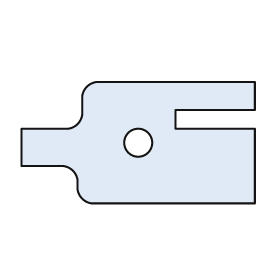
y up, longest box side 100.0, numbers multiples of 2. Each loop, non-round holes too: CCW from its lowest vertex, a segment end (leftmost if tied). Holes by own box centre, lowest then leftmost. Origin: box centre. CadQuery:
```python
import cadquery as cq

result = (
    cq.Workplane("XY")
    .moveTo(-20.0, -26.0)
    .lineTo(50.0, -26.0)
    .lineTo(50.0, 6.0)
    .lineTo(16.0, 6.0)
    .lineTo(16.0, 14.0)
    .lineTo(50.0, 14.0)
    .lineTo(50.0, 26.0)
    .lineTo(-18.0, 26.0)
    .threePointArc((-22.0, 24.0), (-24.0, 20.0))
    .lineTo(-24.0, 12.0)
    .threePointArc((-26.0, 8.0), (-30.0, 6.0))
    .lineTo(-50.0, 6.0)
    .lineTo(-50.0, -10.0)
    .lineTo(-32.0, -10.0)
    .threePointArc((-28.0, -12.0), (-26.0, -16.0))
    .lineTo(-26.0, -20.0)
    .threePointArc((-24.0, -24.0), (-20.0, -26.0))
    .close()
    .moveTo(0.0, 0.0)
    .circle(6.0)
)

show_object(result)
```